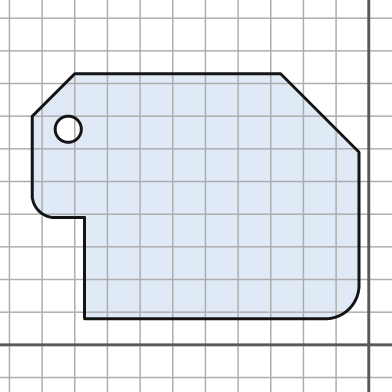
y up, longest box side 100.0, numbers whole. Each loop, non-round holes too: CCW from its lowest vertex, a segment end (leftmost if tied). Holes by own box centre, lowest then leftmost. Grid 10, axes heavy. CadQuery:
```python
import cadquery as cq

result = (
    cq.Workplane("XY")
    .moveTo(-87.0, 8.0)
    .lineTo(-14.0, 8.0)
    .threePointArc((-6.0, 11.0), (-3.0, 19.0))
    .lineTo(-3.0, 59.0)
    .lineTo(-27.0, 83.0)
    .lineTo(-90.0, 83.0)
    .lineTo(-103.0, 70.0)
    .lineTo(-103.0, 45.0)
    .threePointArc((-101.0, 41.0), (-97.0, 39.0))
    .lineTo(-87.0, 39.0)
    .close()
    .moveTo(-92.0, 66.0)
    .circle(4.0)
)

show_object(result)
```